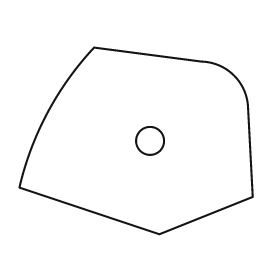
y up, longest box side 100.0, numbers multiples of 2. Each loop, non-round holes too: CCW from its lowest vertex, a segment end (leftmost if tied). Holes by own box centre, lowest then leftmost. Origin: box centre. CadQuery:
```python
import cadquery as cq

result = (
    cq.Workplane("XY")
    .moveTo(10.0, -40.0)
    .lineTo(50.0, -24.0)
    .lineTo(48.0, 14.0)
    .threePointArc((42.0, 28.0), (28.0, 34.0))
    .lineTo(-18.0, 40.0)
    .threePointArc((-38.0, 12.0), (-50.0, -20.0))
    .close()
    .moveTo(6.0, 0.0)
    .circle(6.0)
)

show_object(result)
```